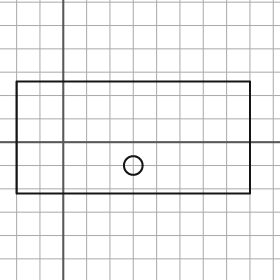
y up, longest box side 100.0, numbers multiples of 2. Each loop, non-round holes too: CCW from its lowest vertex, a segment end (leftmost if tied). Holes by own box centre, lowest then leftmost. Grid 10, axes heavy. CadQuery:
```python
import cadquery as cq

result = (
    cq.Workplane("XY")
    .moveTo(-20.0, -22.0)
    .lineTo(80.0, -22.0)
    .lineTo(80.0, 26.0)
    .lineTo(-20.0, 26.0)
    .close()
    .moveTo(30.0, -10.0)
    .circle(4.0)
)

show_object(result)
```